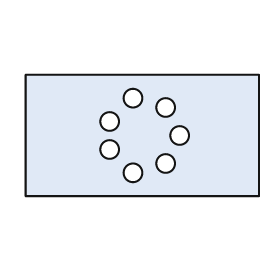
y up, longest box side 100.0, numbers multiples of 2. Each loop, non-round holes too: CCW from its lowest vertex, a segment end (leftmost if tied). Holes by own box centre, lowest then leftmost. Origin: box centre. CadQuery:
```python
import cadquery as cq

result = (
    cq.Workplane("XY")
    .moveTo(-50.0, -26.0)
    .lineTo(50.0, -26.0)
    .lineTo(50.0, 26.0)
    .lineTo(-50.0, 26.0)
    .close()
    .moveTo(-4.0, -16.0)
    .circle(4.0)
    .moveTo(10.0, -12.0)
    .circle(4.0)
    .moveTo(-14.0, -6.0)
    .circle(4.0)
    .moveTo(16.0, 0.0)
    .circle(4.0)
    .moveTo(-14.0, 6.0)
    .circle(4.0)
    .moveTo(10.0, 12.0)
    .circle(4.0)
    .moveTo(-4.0, 16.0)
    .circle(4.0)
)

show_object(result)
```